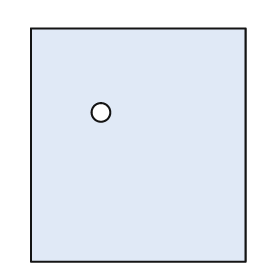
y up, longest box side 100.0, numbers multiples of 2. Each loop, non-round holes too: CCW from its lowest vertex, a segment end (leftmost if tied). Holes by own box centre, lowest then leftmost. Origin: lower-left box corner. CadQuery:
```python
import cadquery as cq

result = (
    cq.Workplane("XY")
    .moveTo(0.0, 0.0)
    .lineTo(92.0, 0.0)
    .lineTo(92.0, 100.0)
    .lineTo(0.0, 100.0)
    .close()
    .moveTo(30.0, 64.0)
    .circle(4.0)
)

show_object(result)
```